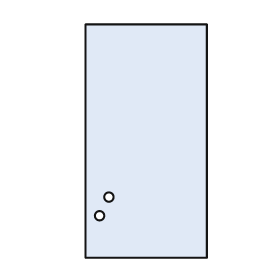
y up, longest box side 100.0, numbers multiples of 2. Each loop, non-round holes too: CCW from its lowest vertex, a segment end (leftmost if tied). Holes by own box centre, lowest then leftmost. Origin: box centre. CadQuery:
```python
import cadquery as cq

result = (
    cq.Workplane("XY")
    .moveTo(-26.0, -50.0)
    .lineTo(26.0, -50.0)
    .lineTo(26.0, 50.0)
    .lineTo(-26.0, 50.0)
    .close()
    .moveTo(-20.0, -32.0)
    .circle(2.0)
    .moveTo(-16.0, -24.0)
    .circle(2.0)
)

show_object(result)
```